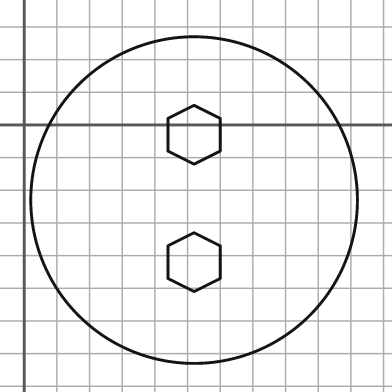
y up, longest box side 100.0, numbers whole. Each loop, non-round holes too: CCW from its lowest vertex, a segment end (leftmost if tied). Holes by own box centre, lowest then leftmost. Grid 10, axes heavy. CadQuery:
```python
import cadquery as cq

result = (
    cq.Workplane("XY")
    .moveTo(52.0, -23.0)
    .circle(50.0)
    .moveTo(52.0, -51.0)
    .lineTo(60.0, -47.0)
    .lineTo(60.0, -37.0)
    .lineTo(52.0, -33.0)
    .lineTo(44.0, -37.0)
    .lineTo(44.0, -47.0)
    .close()
    .moveTo(52.0, -12.0)
    .lineTo(60.0, -8.0)
    .lineTo(60.0, 2.0)
    .lineTo(52.0, 6.0)
    .lineTo(44.0, 2.0)
    .lineTo(44.0, -8.0)
    .close()
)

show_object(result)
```